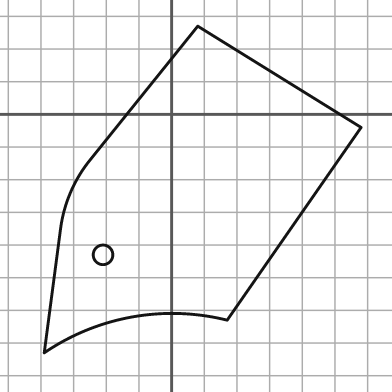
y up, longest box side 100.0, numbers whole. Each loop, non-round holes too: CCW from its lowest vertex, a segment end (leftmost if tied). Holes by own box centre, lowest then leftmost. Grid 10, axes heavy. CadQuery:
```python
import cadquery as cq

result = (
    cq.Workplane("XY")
    .moveTo(-39.0, -73.0)
    .threePointArc((-12.0, -62.0), (17.0, -63.0))
    .lineTo(58.0, -4.0)
    .lineTo(8.0, 27.0)
    .lineTo(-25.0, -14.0)
    .threePointArc((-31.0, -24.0), (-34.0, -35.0))
    .close()
    .moveTo(-21.0, -43.0)
    .circle(3.0)
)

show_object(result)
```